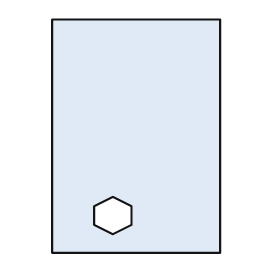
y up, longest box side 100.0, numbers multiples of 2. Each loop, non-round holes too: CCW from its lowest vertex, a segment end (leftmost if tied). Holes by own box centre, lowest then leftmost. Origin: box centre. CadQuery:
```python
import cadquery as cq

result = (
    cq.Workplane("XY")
    .moveTo(-36.0, -50.0)
    .lineTo(36.0, -50.0)
    .lineTo(36.0, 50.0)
    .lineTo(-36.0, 50.0)
    .close()
    .moveTo(-10.0, -42.0)
    .lineTo(-2.0, -38.0)
    .lineTo(-2.0, -30.0)
    .lineTo(-10.0, -26.0)
    .lineTo(-18.0, -30.0)
    .lineTo(-18.0, -38.0)
    .close()
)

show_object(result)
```